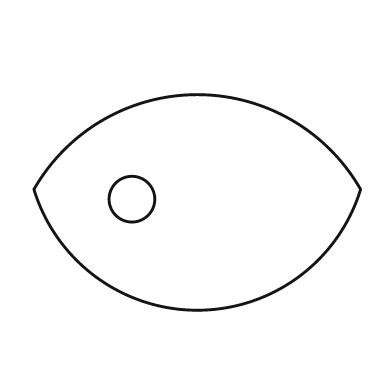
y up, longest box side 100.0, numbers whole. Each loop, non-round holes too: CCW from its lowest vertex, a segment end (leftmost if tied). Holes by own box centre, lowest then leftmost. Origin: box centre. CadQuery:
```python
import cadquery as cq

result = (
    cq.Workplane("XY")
    .moveTo(-50.0, 4.0)
    .threePointArc((0.0, -33.0), (50.0, 4.0))
    .threePointArc((0.0, 33.0), (-50.0, 4.0))
    .close()
    .moveTo(-20.0, 1.0)
    .circle(7.0)
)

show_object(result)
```